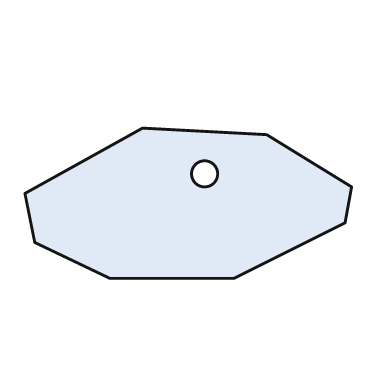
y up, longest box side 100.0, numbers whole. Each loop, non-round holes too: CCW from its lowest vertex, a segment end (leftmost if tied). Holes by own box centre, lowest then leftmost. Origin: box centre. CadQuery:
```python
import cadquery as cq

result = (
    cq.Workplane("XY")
    .moveTo(-24.0, -23.0)
    .lineTo(14.0, -23.0)
    .lineTo(48.0, -6.0)
    .lineTo(50.0, 5.0)
    .lineTo(24.0, 21.0)
    .lineTo(-14.0, 23.0)
    .lineTo(-50.0, 3.0)
    .lineTo(-47.0, -12.0)
    .close()
    .moveTo(5.0, 9.0)
    .circle(4.0)
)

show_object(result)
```